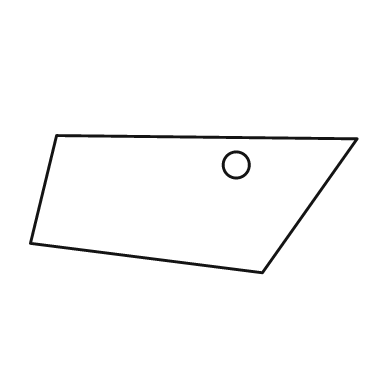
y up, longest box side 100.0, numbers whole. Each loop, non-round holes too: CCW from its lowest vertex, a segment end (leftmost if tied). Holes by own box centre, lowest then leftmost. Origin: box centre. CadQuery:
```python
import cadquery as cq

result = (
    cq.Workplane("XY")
    .moveTo(21.0, -21.0)
    .lineTo(50.0, 20.0)
    .lineTo(-42.0, 21.0)
    .lineTo(-50.0, -12.0)
    .close()
    .moveTo(13.0, 12.0)
    .circle(4.0)
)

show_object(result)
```